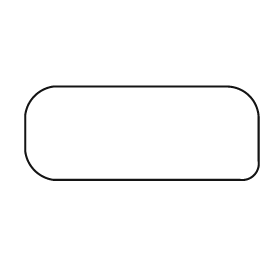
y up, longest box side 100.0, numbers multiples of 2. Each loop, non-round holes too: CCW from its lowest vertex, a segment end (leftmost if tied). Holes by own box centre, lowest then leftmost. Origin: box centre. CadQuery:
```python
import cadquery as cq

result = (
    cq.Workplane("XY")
    .moveTo(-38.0, -20.0)
    .lineTo(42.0, -20.0)
    .threePointArc((48.0, -18.0), (50.0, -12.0))
    .lineTo(50.0, 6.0)
    .threePointArc((46.0, 16.0), (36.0, 20.0))
    .lineTo(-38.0, 20.0)
    .threePointArc((-46.0, 16.0), (-50.0, 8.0))
    .lineTo(-50.0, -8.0)
    .threePointArc((-46.0, -16.0), (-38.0, -20.0))
    .close()
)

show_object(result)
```